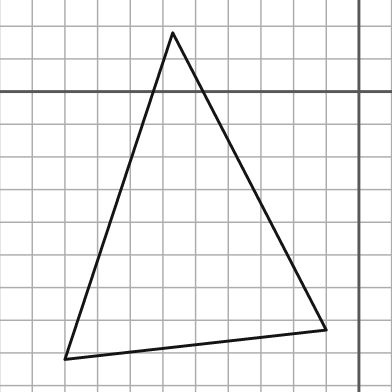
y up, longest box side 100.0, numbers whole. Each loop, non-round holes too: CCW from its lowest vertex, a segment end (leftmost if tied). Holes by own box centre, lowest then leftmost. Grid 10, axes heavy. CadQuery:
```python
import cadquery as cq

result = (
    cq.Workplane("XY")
    .moveTo(-90.0, -82.0)
    .lineTo(-10.0, -73.0)
    .lineTo(-57.0, 18.0)
    .close()
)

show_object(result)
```